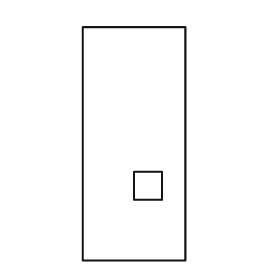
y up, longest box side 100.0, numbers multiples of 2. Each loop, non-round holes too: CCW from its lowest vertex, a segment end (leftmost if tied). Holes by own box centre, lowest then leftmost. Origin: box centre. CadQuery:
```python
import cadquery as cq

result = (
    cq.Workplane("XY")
    .moveTo(-22.0, -50.0)
    .lineTo(22.0, -50.0)
    .lineTo(22.0, 50.0)
    .lineTo(-22.0, 50.0)
    .close()
    .moveTo(0.0, -24.0)
    .lineTo(12.0, -24.0)
    .lineTo(12.0, -12.0)
    .lineTo(0.0, -12.0)
    .close()
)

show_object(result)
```